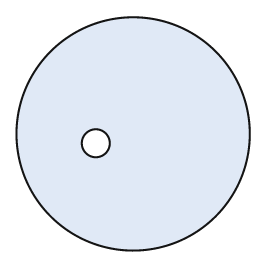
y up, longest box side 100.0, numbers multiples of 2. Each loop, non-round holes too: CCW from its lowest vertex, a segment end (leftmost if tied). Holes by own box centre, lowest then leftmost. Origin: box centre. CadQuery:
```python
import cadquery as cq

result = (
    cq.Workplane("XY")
    .moveTo(0.0, 0.0)
    .circle(50.0)
    .moveTo(-16.0, -4.0)
    .circle(6.0)
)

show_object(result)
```